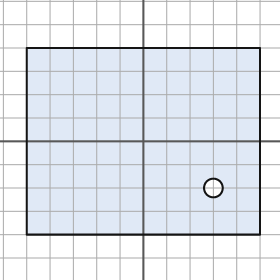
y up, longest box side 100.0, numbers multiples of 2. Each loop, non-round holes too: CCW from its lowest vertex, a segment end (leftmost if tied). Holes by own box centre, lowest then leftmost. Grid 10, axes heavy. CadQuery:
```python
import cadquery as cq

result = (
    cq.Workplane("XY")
    .moveTo(-50.0, -40.0)
    .lineTo(50.0, -40.0)
    .lineTo(50.0, 40.0)
    .lineTo(-50.0, 40.0)
    .close()
    .moveTo(30.0, -20.0)
    .circle(4.0)
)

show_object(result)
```